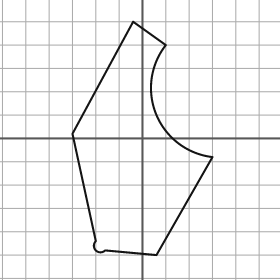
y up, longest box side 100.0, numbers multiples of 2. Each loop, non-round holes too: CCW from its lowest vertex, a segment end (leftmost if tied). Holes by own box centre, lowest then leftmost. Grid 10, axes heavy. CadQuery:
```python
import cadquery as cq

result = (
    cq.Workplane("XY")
    .moveTo(6.0, -50.0)
    .lineTo(30.0, -8.0)
    .threePointArc((6.0, 10.0), (10.0, 40.0))
    .lineTo(-4.0, 50.0)
    .lineTo(-30.0, 2.0)
    .lineTo(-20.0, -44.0)
    .threePointArc((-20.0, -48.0), (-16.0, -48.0))
    .close()
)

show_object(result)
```